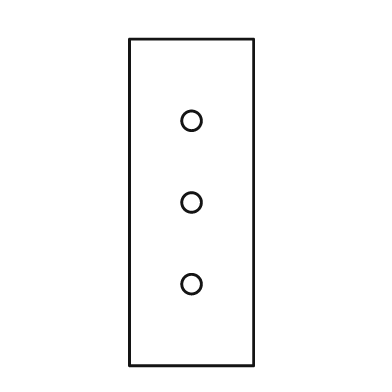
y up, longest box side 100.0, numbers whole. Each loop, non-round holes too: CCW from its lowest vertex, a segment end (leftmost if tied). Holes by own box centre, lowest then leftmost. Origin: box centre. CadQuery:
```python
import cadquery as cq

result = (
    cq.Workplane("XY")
    .moveTo(-19.0, -50.0)
    .lineTo(19.0, -50.0)
    .lineTo(19.0, 50.0)
    .lineTo(-19.0, 50.0)
    .close()
    .moveTo(0.0, -25.0)
    .circle(3.0)
    .moveTo(0.0, 0.0)
    .circle(3.0)
    .moveTo(0.0, 25.0)
    .circle(3.0)
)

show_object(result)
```